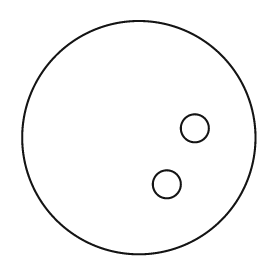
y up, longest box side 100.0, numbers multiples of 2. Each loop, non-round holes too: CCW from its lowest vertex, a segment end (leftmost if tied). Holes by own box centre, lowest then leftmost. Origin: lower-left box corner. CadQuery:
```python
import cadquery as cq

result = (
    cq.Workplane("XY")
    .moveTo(50.0, 50.0)
    .circle(50.0)
    .moveTo(62.0, 30.0)
    .circle(6.0)
    .moveTo(74.0, 54.0)
    .circle(6.0)
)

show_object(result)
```